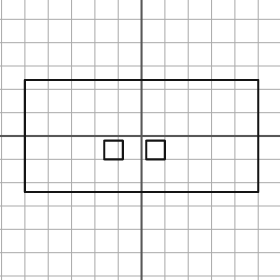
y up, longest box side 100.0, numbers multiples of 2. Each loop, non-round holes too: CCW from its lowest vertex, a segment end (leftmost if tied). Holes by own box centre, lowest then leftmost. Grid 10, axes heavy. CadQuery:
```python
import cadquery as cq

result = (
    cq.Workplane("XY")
    .moveTo(-50.0, -24.0)
    .lineTo(50.0, -24.0)
    .lineTo(50.0, 24.0)
    .lineTo(-50.0, 24.0)
    .close()
    .moveTo(-16.0, -10.0)
    .lineTo(-8.0, -10.0)
    .lineTo(-8.0, -2.0)
    .lineTo(-16.0, -2.0)
    .close()
    .moveTo(2.0, -10.0)
    .lineTo(10.0, -10.0)
    .lineTo(10.0, -2.0)
    .lineTo(2.0, -2.0)
    .close()
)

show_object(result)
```